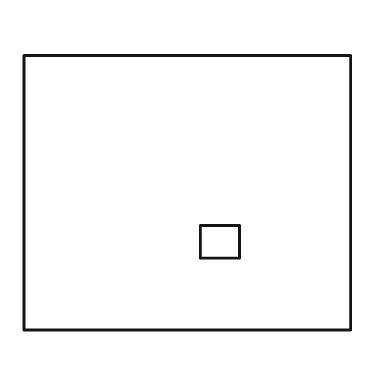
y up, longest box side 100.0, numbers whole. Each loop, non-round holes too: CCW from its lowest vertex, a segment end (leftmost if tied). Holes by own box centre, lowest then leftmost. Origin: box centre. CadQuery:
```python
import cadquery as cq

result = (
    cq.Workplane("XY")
    .moveTo(-50.0, -42.0)
    .lineTo(50.0, -42.0)
    .lineTo(50.0, 42.0)
    .lineTo(-50.0, 42.0)
    .close()
    .moveTo(4.0, -20.0)
    .lineTo(16.0, -20.0)
    .lineTo(16.0, -10.0)
    .lineTo(4.0, -10.0)
    .close()
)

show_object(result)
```